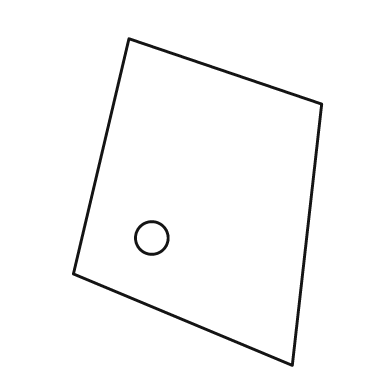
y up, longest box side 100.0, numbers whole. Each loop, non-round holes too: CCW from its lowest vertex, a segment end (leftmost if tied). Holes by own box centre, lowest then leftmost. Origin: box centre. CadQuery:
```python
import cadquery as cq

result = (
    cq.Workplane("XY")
    .moveTo(29.0, -50.0)
    .lineTo(38.0, 30.0)
    .lineTo(-21.0, 50.0)
    .lineTo(-38.0, -22.0)
    .close()
    .moveTo(-14.0, -11.0)
    .circle(5.0)
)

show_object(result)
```